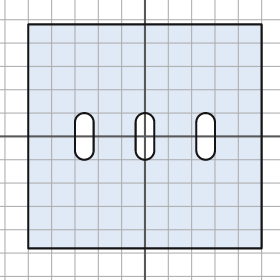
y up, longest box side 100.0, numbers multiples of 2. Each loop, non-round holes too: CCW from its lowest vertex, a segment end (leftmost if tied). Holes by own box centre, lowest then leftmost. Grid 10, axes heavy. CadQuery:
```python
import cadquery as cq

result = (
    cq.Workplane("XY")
    .moveTo(-50.0, -48.0)
    .lineTo(50.0, -48.0)
    .lineTo(50.0, 48.0)
    .lineTo(-50.0, 48.0)
    .close()
    .moveTo(-30.0, -6.0)
    .threePointArc((-26.0, -10.0), (-22.0, -6.0))
    .lineTo(-22.0, 6.0)
    .threePointArc((-26.0, 10.0), (-30.0, 6.0))
    .close()
    .moveTo(-4.0, -6.0)
    .threePointArc((0.0, -10.0), (4.0, -6.0))
    .lineTo(4.0, 6.0)
    .threePointArc((0.0, 10.0), (-4.0, 6.0))
    .close()
    .moveTo(22.0, -6.0)
    .threePointArc((26.0, -10.0), (30.0, -6.0))
    .lineTo(30.0, 6.0)
    .threePointArc((26.0, 10.0), (22.0, 6.0))
    .close()
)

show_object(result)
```